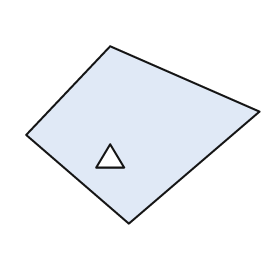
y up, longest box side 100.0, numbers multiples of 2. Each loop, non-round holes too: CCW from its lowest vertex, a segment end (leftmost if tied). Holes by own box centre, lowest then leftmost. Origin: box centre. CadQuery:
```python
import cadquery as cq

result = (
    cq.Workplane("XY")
    .moveTo(-6.0, -38.0)
    .lineTo(50.0, 10.0)
    .lineTo(-14.0, 38.0)
    .lineTo(-50.0, 0.0)
    .close()
    .moveTo(-20.0, -14.0)
    .lineTo(-8.0, -14.0)
    .lineTo(-14.0, -4.0)
    .close()
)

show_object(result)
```